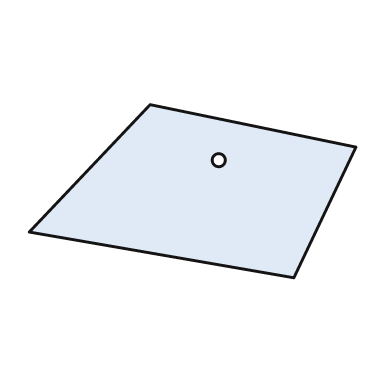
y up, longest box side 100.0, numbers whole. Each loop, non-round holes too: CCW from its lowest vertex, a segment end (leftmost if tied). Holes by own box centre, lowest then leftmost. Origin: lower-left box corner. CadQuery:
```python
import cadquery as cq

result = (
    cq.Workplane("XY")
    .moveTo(81.0, 0.0)
    .lineTo(100.0, 40.0)
    .lineTo(37.0, 53.0)
    .lineTo(0.0, 14.0)
    .close()
    .moveTo(58.0, 36.0)
    .circle(2.0)
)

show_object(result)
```